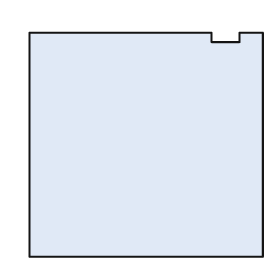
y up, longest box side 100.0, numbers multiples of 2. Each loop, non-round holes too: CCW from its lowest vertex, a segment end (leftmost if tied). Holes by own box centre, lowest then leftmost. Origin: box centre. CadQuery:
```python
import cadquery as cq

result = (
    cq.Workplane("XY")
    .moveTo(-50.0, -48.0)
    .lineTo(50.0, -48.0)
    .lineTo(50.0, 48.0)
    .lineTo(40.0, 48.0)
    .lineTo(40.0, 44.0)
    .lineTo(28.0, 44.0)
    .lineTo(28.0, 48.0)
    .lineTo(-50.0, 48.0)
    .close()
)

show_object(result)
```